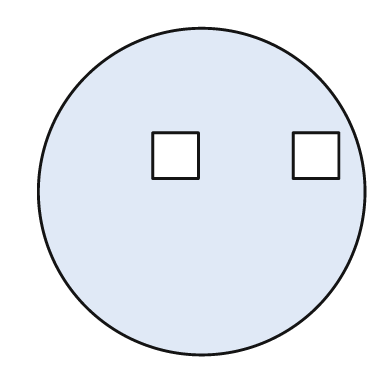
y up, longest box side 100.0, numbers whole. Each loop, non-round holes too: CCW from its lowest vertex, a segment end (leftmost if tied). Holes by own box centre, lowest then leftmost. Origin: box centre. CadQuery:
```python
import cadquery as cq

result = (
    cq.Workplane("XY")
    .moveTo(0.0, 0.0)
    .circle(50.0)
    .moveTo(-15.0, 4.0)
    .lineTo(-1.0, 4.0)
    .lineTo(-1.0, 18.0)
    .lineTo(-15.0, 18.0)
    .close()
    .moveTo(28.0, 4.0)
    .lineTo(42.0, 4.0)
    .lineTo(42.0, 18.0)
    .lineTo(28.0, 18.0)
    .close()
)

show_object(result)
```